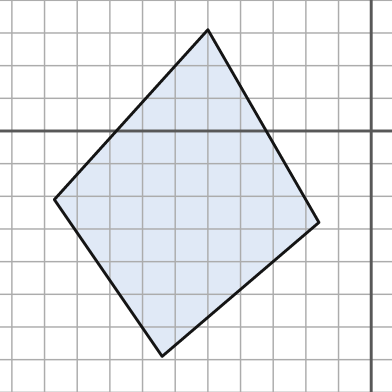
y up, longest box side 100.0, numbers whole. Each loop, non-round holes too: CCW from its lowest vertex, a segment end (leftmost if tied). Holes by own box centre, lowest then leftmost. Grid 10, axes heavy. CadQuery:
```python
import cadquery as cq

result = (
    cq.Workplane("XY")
    .moveTo(-64.0, -69.0)
    .lineTo(-16.0, -28.0)
    .lineTo(-50.0, 31.0)
    .lineTo(-97.0, -21.0)
    .close()
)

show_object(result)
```